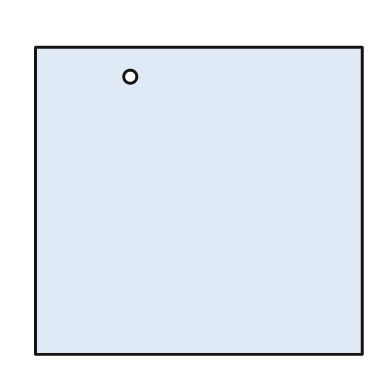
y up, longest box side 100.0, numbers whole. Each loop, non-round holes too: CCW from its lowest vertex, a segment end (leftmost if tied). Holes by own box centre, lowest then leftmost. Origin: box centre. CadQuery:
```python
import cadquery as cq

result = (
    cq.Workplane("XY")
    .moveTo(-50.0, -47.0)
    .lineTo(50.0, -47.0)
    .lineTo(50.0, 47.0)
    .lineTo(-50.0, 47.0)
    .close()
    .moveTo(-21.0, 38.0)
    .circle(2.0)
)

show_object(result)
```